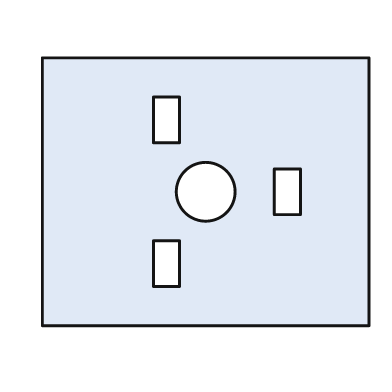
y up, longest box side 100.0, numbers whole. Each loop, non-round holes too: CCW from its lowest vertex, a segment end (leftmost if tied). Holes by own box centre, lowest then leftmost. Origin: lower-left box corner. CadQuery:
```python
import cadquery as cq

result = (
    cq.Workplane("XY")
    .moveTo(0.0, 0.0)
    .lineTo(100.0, 0.0)
    .lineTo(100.0, 82.0)
    .lineTo(0.0, 82.0)
    .close()
    .moveTo(34.0, 12.0)
    .lineTo(42.0, 12.0)
    .lineTo(42.0, 26.0)
    .lineTo(34.0, 26.0)
    .close()
    .moveTo(50.0, 41.0)
    .circle(9.0)
    .moveTo(71.0, 34.0)
    .lineTo(79.0, 34.0)
    .lineTo(79.0, 48.0)
    .lineTo(71.0, 48.0)
    .close()
    .moveTo(34.0, 56.0)
    .lineTo(42.0, 56.0)
    .lineTo(42.0, 70.0)
    .lineTo(34.0, 70.0)
    .close()
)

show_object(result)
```